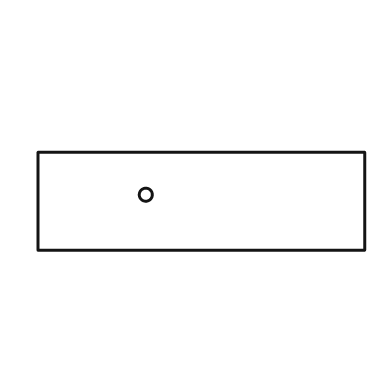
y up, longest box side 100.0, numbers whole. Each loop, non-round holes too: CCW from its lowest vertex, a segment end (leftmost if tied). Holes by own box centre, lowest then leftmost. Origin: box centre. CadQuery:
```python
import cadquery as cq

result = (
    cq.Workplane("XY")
    .moveTo(-50.0, -15.0)
    .lineTo(50.0, -15.0)
    .lineTo(50.0, 15.0)
    .lineTo(-50.0, 15.0)
    .close()
    .moveTo(-17.0, 2.0)
    .circle(2.0)
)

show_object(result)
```